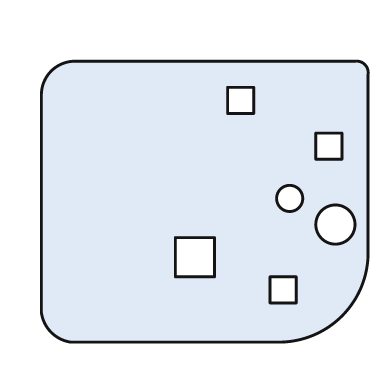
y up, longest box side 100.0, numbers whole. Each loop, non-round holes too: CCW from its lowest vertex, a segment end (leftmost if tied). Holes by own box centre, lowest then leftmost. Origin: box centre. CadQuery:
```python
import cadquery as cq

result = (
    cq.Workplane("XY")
    .moveTo(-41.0, -43.0)
    .lineTo(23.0, -43.0)
    .threePointArc((42.0, -35.0), (50.0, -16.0))
    .lineTo(50.0, 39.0)
    .threePointArc((49.0, 42.0), (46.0, 43.0))
    .lineTo(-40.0, 43.0)
    .threePointArc((-47.0, 40.0), (-50.0, 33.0))
    .lineTo(-50.0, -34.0)
    .threePointArc((-47.0, -40.0), (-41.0, -43.0))
    .close()
    .moveTo(20.0, -31.0)
    .lineTo(28.0, -31.0)
    .lineTo(28.0, -23.0)
    .lineTo(20.0, -23.0)
    .close()
    .moveTo(-9.0, -23.0)
    .lineTo(3.0, -23.0)
    .lineTo(3.0, -11.0)
    .lineTo(-9.0, -11.0)
    .close()
    .moveTo(40.0, -7.0)
    .circle(6.0)
    .moveTo(26.0, 1.0)
    .circle(4.0)
    .moveTo(34.0, 13.0)
    .lineTo(42.0, 13.0)
    .lineTo(42.0, 21.0)
    .lineTo(34.0, 21.0)
    .close()
    .moveTo(7.0, 27.0)
    .lineTo(15.0, 27.0)
    .lineTo(15.0, 35.0)
    .lineTo(7.0, 35.0)
    .close()
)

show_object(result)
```